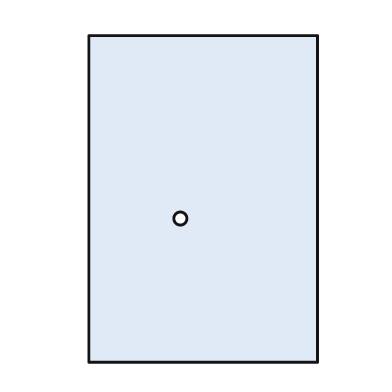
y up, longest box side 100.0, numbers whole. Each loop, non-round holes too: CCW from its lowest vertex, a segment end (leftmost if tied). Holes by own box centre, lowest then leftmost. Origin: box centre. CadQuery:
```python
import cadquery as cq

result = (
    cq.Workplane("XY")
    .moveTo(-35.0, -50.0)
    .lineTo(35.0, -50.0)
    .lineTo(35.0, 50.0)
    .lineTo(-35.0, 50.0)
    .close()
    .moveTo(-7.0, -6.0)
    .circle(2.0)
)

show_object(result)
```